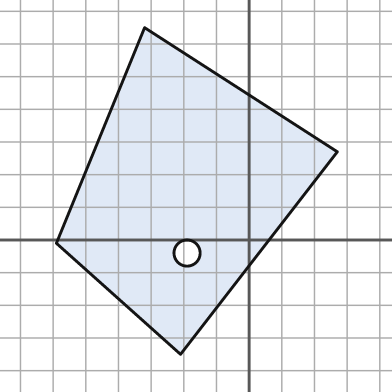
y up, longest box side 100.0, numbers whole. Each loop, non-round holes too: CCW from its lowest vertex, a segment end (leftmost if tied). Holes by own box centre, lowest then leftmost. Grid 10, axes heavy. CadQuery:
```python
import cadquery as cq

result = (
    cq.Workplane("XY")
    .moveTo(-21.0, -35.0)
    .lineTo(27.0, 27.0)
    .lineTo(-32.0, 65.0)
    .lineTo(-59.0, -1.0)
    .close()
    .moveTo(-19.0, -4.0)
    .circle(4.0)
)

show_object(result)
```